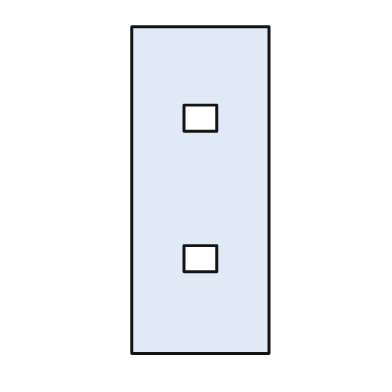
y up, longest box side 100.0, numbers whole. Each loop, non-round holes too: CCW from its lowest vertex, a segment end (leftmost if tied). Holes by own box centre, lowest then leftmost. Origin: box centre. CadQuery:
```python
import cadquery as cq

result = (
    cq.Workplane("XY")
    .moveTo(-21.0, -50.0)
    .lineTo(21.0, -50.0)
    .lineTo(21.0, 50.0)
    .lineTo(-21.0, 50.0)
    .close()
    .moveTo(-5.0, -25.0)
    .lineTo(5.0, -25.0)
    .lineTo(5.0, -17.0)
    .lineTo(-5.0, -17.0)
    .close()
    .moveTo(-5.0, 18.0)
    .lineTo(5.0, 18.0)
    .lineTo(5.0, 26.0)
    .lineTo(-5.0, 26.0)
    .close()
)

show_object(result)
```